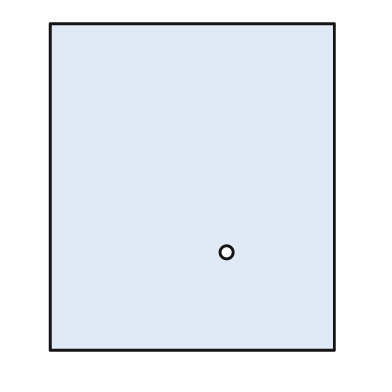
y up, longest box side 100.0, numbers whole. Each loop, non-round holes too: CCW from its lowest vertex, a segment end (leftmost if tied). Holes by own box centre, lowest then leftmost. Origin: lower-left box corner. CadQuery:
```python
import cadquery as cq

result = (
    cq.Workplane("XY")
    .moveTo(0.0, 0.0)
    .lineTo(87.0, 0.0)
    .lineTo(87.0, 100.0)
    .lineTo(0.0, 100.0)
    .close()
    .moveTo(54.0, 30.0)
    .circle(2.0)
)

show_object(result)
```